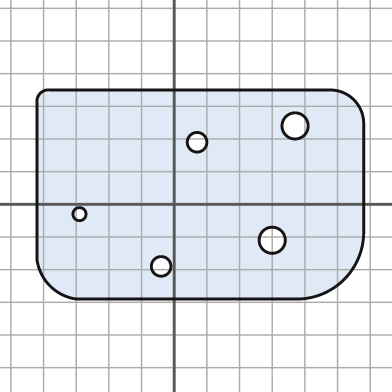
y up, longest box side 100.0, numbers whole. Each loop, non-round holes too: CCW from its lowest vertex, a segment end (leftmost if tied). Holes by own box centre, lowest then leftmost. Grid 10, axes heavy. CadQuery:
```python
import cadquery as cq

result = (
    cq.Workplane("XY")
    .moveTo(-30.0, -29.0)
    .lineTo(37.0, -29.0)
    .threePointArc((52.0, -23.0), (58.0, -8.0))
    .lineTo(58.0, 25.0)
    .threePointArc((55.0, 32.0), (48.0, 35.0))
    .lineTo(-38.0, 35.0)
    .threePointArc((-41.0, 34.0), (-42.0, 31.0))
    .lineTo(-42.0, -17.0)
    .threePointArc((-38.0, -25.0), (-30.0, -29.0))
    .close()
    .moveTo(-4.0, -19.0)
    .circle(3.0)
    .moveTo(30.0, -11.0)
    .circle(4.0)
    .moveTo(-29.0, -3.0)
    .circle(2.0)
    .moveTo(7.0, 19.0)
    .circle(3.0)
    .moveTo(37.0, 24.0)
    .circle(4.0)
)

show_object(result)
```